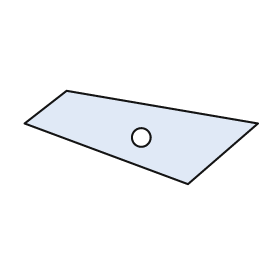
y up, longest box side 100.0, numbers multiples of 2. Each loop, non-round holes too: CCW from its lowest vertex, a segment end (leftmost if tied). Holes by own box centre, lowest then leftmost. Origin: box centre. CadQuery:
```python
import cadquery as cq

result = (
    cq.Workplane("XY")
    .moveTo(20.0, -20.0)
    .lineTo(50.0, 6.0)
    .lineTo(-32.0, 20.0)
    .lineTo(-50.0, 6.0)
    .close()
    .moveTo(0.0, 0.0)
    .circle(4.0)
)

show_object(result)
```